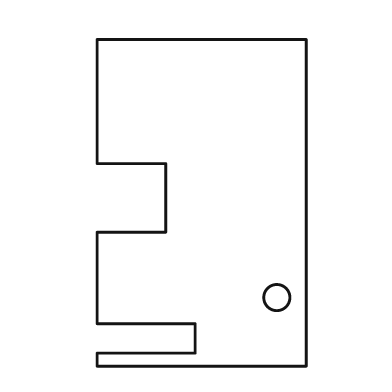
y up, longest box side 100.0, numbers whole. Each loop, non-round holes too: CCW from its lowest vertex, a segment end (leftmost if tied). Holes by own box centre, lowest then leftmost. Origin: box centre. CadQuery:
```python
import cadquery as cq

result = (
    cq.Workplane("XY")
    .moveTo(-32.0, -50.0)
    .lineTo(32.0, -50.0)
    .lineTo(32.0, 50.0)
    .lineTo(-32.0, 50.0)
    .lineTo(-32.0, 12.0)
    .lineTo(-11.0, 12.0)
    .lineTo(-11.0, -9.0)
    .lineTo(-32.0, -9.0)
    .lineTo(-32.0, -37.0)
    .lineTo(-2.0, -37.0)
    .lineTo(-2.0, -46.0)
    .lineTo(-32.0, -46.0)
    .close()
    .moveTo(23.0, -29.0)
    .circle(4.0)
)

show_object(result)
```